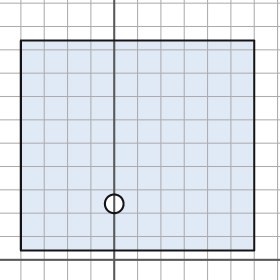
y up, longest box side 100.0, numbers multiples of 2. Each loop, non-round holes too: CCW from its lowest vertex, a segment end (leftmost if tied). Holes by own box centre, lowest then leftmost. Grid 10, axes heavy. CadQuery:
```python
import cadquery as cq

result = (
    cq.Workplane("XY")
    .moveTo(-40.0, 4.0)
    .lineTo(60.0, 4.0)
    .lineTo(60.0, 94.0)
    .lineTo(-40.0, 94.0)
    .close()
    .moveTo(0.0, 24.0)
    .circle(4.0)
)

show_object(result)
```